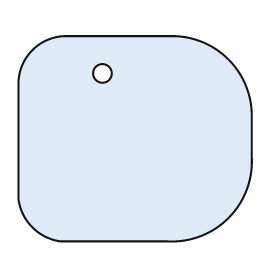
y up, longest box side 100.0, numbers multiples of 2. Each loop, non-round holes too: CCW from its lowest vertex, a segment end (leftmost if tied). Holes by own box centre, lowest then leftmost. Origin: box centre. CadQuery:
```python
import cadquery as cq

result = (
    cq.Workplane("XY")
    .moveTo(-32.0, -44.0)
    .lineTo(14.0, -44.0)
    .threePointArc((40.0, -34.0), (50.0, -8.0))
    .lineTo(50.0, 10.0)
    .threePointArc((40.0, 34.0), (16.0, 44.0))
    .lineTo(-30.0, 44.0)
    .threePointArc((-44.0, 38.0), (-50.0, 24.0))
    .lineTo(-50.0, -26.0)
    .threePointArc((-44.0, -38.0), (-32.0, -44.0))
    .close()
    .moveTo(-14.0, 28.0)
    .circle(4.0)
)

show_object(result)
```